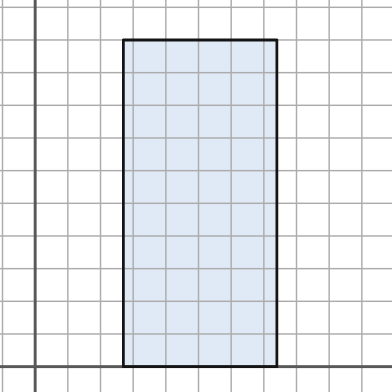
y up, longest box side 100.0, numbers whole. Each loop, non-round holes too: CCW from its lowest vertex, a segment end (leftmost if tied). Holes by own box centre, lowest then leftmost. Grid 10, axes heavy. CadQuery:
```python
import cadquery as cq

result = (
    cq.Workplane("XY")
    .moveTo(27.0, 0.0)
    .lineTo(74.0, 0.0)
    .lineTo(74.0, 100.0)
    .lineTo(27.0, 100.0)
    .close()
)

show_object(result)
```